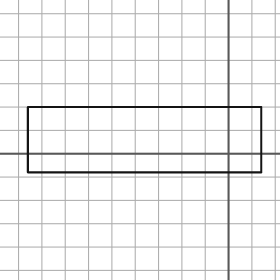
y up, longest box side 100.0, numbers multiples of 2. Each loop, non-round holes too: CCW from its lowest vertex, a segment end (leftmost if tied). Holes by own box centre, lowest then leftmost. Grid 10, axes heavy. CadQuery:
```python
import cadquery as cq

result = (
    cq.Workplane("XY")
    .moveTo(-86.0, -8.0)
    .lineTo(14.0, -8.0)
    .lineTo(14.0, 20.0)
    .lineTo(-86.0, 20.0)
    .close()
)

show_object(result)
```